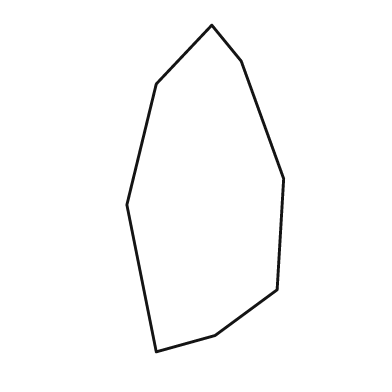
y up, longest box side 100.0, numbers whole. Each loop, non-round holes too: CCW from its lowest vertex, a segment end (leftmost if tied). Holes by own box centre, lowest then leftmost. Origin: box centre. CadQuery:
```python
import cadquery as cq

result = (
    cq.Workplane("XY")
    .moveTo(-15.0, -50.0)
    .lineTo(3.0, -45.0)
    .lineTo(22.0, -31.0)
    .lineTo(24.0, 3.0)
    .lineTo(11.0, 39.0)
    .lineTo(2.0, 50.0)
    .lineTo(-15.0, 32.0)
    .lineTo(-24.0, -5.0)
    .close()
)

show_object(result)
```